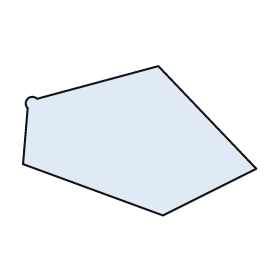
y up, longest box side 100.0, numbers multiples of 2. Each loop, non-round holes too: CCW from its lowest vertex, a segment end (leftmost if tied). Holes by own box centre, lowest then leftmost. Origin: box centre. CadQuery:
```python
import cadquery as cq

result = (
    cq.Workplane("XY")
    .moveTo(10.0, -32.0)
    .lineTo(50.0, -12.0)
    .lineTo(8.0, 32.0)
    .lineTo(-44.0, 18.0)
    .threePointArc((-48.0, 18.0), (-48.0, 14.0))
    .lineTo(-50.0, -10.0)
    .close()
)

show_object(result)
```